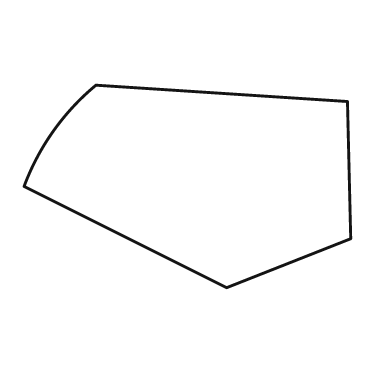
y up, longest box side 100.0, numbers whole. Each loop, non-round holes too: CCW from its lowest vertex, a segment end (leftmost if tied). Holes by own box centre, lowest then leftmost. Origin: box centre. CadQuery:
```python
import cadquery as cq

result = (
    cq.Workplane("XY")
    .moveTo(12.0, -31.0)
    .lineTo(50.0, -16.0)
    .lineTo(49.0, 26.0)
    .lineTo(-28.0, 31.0)
    .threePointArc((-41.0, 17.0), (-50.0, 0.0))
    .close()
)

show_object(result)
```